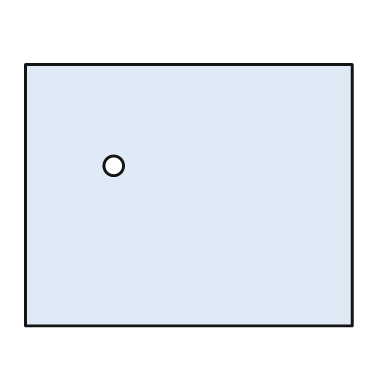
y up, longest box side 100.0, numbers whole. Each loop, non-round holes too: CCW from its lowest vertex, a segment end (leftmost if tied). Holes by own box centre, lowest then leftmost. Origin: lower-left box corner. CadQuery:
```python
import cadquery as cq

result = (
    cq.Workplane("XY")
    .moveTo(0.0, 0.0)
    .lineTo(100.0, 0.0)
    .lineTo(100.0, 80.0)
    .lineTo(0.0, 80.0)
    .close()
    .moveTo(27.0, 49.0)
    .circle(3.0)
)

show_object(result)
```